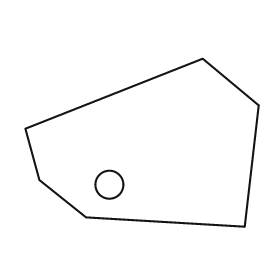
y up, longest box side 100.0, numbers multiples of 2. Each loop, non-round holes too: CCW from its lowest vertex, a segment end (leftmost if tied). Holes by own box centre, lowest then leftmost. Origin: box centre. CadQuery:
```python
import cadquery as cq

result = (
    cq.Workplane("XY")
    .moveTo(44.0, -36.0)
    .lineTo(50.0, 16.0)
    .lineTo(26.0, 36.0)
    .lineTo(-50.0, 6.0)
    .lineTo(-44.0, -16.0)
    .lineTo(-24.0, -32.0)
    .close()
    .moveTo(-14.0, -18.0)
    .circle(6.0)
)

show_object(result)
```